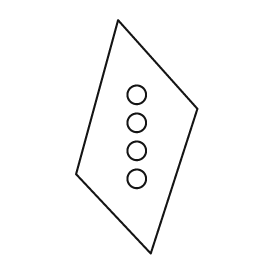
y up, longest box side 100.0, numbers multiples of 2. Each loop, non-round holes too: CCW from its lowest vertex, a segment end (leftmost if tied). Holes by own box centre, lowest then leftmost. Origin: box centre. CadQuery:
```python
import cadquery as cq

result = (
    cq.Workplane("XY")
    .moveTo(6.0, -50.0)
    .lineTo(26.0, 12.0)
    .lineTo(-8.0, 50.0)
    .lineTo(-26.0, -16.0)
    .close()
    .moveTo(0.0, -18.0)
    .circle(4.0)
    .moveTo(0.0, -6.0)
    .circle(4.0)
    .moveTo(0.0, 6.0)
    .circle(4.0)
    .moveTo(0.0, 18.0)
    .circle(4.0)
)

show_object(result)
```